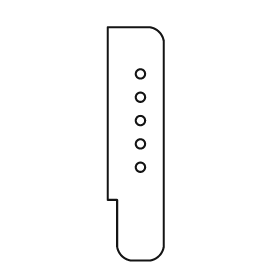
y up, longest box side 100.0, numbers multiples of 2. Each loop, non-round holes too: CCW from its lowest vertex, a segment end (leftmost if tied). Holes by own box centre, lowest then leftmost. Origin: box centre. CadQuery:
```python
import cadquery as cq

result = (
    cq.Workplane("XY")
    .moveTo(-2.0, -50.0)
    .lineTo(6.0, -50.0)
    .threePointArc((10.0, -48.0), (12.0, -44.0))
    .lineTo(12.0, 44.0)
    .threePointArc((10.0, 48.0), (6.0, 50.0))
    .lineTo(-12.0, 50.0)
    .lineTo(-12.0, -24.0)
    .lineTo(-8.0, -24.0)
    .lineTo(-8.0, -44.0)
    .threePointArc((-6.0, -48.0), (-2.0, -50.0))
    .close()
    .moveTo(2.0, -10.0)
    .circle(2.0)
    .moveTo(2.0, 0.0)
    .circle(2.0)
    .moveTo(2.0, 10.0)
    .circle(2.0)
    .moveTo(2.0, 20.0)
    .circle(2.0)
    .moveTo(2.0, 30.0)
    .circle(2.0)
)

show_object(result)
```